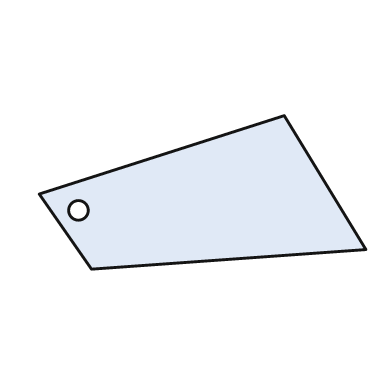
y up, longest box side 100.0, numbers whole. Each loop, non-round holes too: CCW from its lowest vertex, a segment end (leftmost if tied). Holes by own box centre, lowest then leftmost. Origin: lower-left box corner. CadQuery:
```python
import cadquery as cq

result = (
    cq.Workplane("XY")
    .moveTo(16.0, 0.0)
    .lineTo(100.0, 6.0)
    .lineTo(75.0, 47.0)
    .lineTo(0.0, 23.0)
    .close()
    .moveTo(12.0, 18.0)
    .circle(3.0)
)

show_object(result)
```